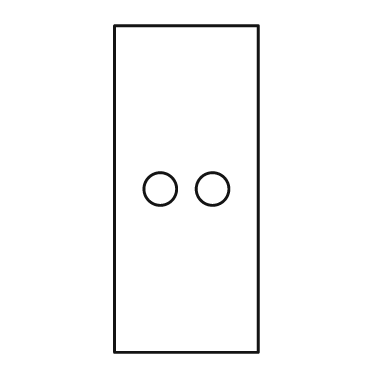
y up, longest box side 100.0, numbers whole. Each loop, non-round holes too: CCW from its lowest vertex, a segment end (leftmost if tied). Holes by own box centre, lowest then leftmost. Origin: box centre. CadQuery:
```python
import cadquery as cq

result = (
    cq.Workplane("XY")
    .moveTo(-22.0, -50.0)
    .lineTo(22.0, -50.0)
    .lineTo(22.0, 50.0)
    .lineTo(-22.0, 50.0)
    .close()
    .moveTo(-8.0, 0.0)
    .circle(5.0)
    .moveTo(8.0, 0.0)
    .circle(5.0)
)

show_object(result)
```